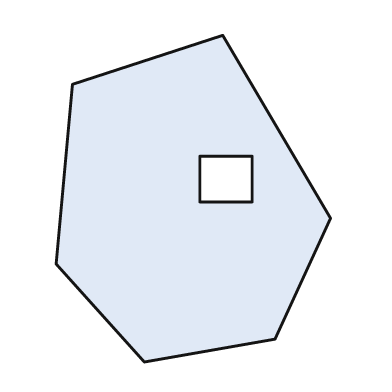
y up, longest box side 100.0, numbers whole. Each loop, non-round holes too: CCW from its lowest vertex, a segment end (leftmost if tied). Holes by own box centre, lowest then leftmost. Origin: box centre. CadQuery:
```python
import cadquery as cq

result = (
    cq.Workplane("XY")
    .moveTo(-15.0, -50.0)
    .lineTo(25.0, -43.0)
    .lineTo(42.0, -6.0)
    .lineTo(9.0, 50.0)
    .lineTo(-37.0, 35.0)
    .lineTo(-42.0, -20.0)
    .close()
    .moveTo(2.0, -1.0)
    .lineTo(18.0, -1.0)
    .lineTo(18.0, 13.0)
    .lineTo(2.0, 13.0)
    .close()
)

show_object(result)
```